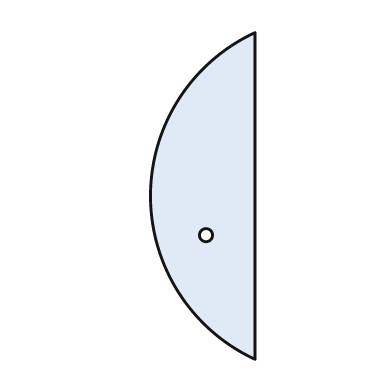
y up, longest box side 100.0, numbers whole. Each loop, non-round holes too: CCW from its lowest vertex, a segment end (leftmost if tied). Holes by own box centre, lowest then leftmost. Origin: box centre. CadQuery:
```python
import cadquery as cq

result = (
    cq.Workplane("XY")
    .moveTo(16.0, -50.0)
    .lineTo(16.0, 50.0)
    .threePointArc((-16.0, 0.0), (16.0, -50.0))
    .close()
    .moveTo(1.0, -12.0)
    .circle(2.0)
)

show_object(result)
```